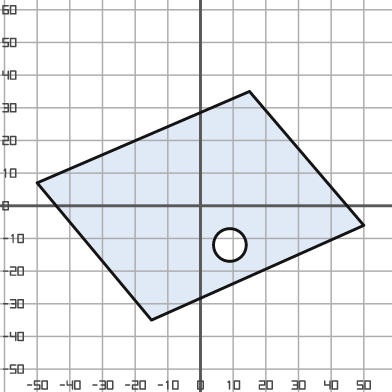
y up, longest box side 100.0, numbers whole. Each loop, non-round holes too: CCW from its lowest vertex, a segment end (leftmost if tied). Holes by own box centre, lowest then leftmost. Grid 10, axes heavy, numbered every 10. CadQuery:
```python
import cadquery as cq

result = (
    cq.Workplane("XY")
    .moveTo(-15.0, -35.0)
    .lineTo(50.0, -6.0)
    .lineTo(15.0, 35.0)
    .lineTo(-50.0, 7.0)
    .close()
    .moveTo(9.0, -12.0)
    .circle(5.0)
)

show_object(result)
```